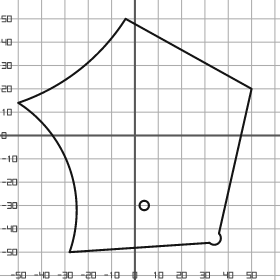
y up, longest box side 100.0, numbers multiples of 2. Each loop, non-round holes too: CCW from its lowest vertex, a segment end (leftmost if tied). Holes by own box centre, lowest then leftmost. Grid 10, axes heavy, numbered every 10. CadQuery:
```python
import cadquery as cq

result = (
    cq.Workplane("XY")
    .moveTo(-28.0, -50.0)
    .lineTo(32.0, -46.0)
    .threePointArc((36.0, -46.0), (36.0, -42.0))
    .lineTo(50.0, 20.0)
    .lineTo(-4.0, 50.0)
    .threePointArc((-24.0, 28.0), (-50.0, 14.0))
    .threePointArc((-28.0, -14.0), (-28.0, -50.0))
    .close()
    .moveTo(4.0, -30.0)
    .circle(2.0)
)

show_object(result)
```